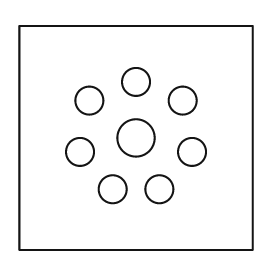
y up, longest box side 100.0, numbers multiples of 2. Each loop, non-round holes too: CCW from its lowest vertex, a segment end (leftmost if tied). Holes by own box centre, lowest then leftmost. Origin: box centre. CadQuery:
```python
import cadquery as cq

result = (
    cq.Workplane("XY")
    .moveTo(-50.0, -48.0)
    .lineTo(50.0, -48.0)
    .lineTo(50.0, 48.0)
    .lineTo(-50.0, 48.0)
    .close()
    .moveTo(-10.0, -22.0)
    .circle(6.0)
    .moveTo(10.0, -22.0)
    .circle(6.0)
    .moveTo(-24.0, -6.0)
    .circle(6.0)
    .moveTo(24.0, -6.0)
    .circle(6.0)
    .moveTo(0.0, 0.0)
    .circle(8.0)
    .moveTo(-20.0, 16.0)
    .circle(6.0)
    .moveTo(20.0, 16.0)
    .circle(6.0)
    .moveTo(0.0, 24.0)
    .circle(6.0)
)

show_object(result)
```